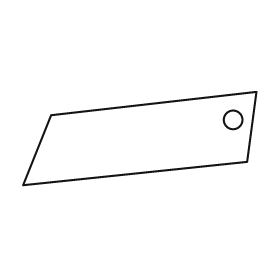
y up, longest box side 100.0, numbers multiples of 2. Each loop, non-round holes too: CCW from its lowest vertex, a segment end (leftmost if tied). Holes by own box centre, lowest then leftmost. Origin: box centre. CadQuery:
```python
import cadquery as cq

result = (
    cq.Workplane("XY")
    .moveTo(-50.0, -20.0)
    .lineTo(46.0, -10.0)
    .lineTo(50.0, 20.0)
    .lineTo(-38.0, 10.0)
    .close()
    .moveTo(40.0, 8.0)
    .circle(4.0)
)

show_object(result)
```